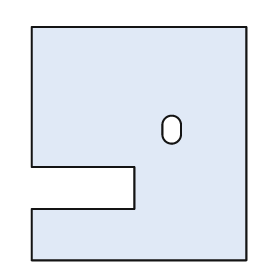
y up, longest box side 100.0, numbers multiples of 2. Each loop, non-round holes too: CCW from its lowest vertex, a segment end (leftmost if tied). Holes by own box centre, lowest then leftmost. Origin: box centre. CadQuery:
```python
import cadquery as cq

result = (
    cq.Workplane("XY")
    .moveTo(-46.0, -50.0)
    .lineTo(46.0, -50.0)
    .lineTo(46.0, 50.0)
    .lineTo(-46.0, 50.0)
    .lineTo(-46.0, -10.0)
    .lineTo(-2.0, -10.0)
    .lineTo(-2.0, -28.0)
    .lineTo(-46.0, -28.0)
    .close()
    .moveTo(10.0, 4.0)
    .threePointArc((14.0, 0.0), (18.0, 4.0))
    .lineTo(18.0, 8.0)
    .threePointArc((14.0, 12.0), (10.0, 8.0))
    .close()
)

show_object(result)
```